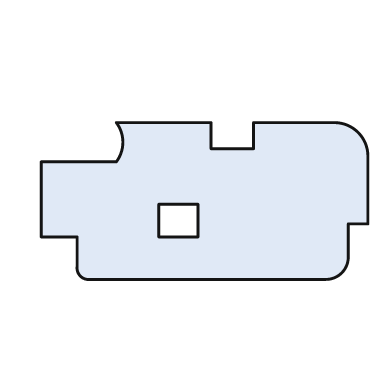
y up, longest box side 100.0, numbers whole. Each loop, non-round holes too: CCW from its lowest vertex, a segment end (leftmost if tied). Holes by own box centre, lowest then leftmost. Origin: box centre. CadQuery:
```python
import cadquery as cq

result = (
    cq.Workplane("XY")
    .moveTo(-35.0, -24.0)
    .lineTo(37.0, -24.0)
    .threePointArc((42.0, -22.0), (44.0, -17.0))
    .lineTo(44.0, -7.0)
    .lineTo(50.0, -7.0)
    .lineTo(50.0, 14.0)
    .threePointArc((47.0, 21.0), (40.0, 24.0))
    .lineTo(15.0, 24.0)
    .lineTo(15.0, 16.0)
    .lineTo(2.0, 16.0)
    .lineTo(2.0, 24.0)
    .lineTo(-27.0, 24.0)
    .threePointArc((-25.0, 18.0), (-27.0, 12.0))
    .lineTo(-50.0, 12.0)
    .lineTo(-50.0, -11.0)
    .lineTo(-39.0, -11.0)
    .lineTo(-39.0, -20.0)
    .threePointArc((-38.0, -23.0), (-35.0, -24.0))
    .close()
    .moveTo(-14.0, -11.0)
    .lineTo(-2.0, -11.0)
    .lineTo(-2.0, -1.0)
    .lineTo(-14.0, -1.0)
    .close()
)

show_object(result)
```